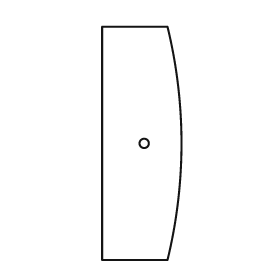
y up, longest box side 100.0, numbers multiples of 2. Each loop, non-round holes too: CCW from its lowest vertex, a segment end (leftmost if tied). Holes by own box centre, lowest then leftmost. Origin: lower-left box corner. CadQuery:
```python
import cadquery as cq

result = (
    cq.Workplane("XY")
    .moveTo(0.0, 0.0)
    .lineTo(28.0, 0.0)
    .threePointArc((34.0, 50.0), (28.0, 100.0))
    .lineTo(0.0, 100.0)
    .close()
    .moveTo(18.0, 50.0)
    .circle(2.0)
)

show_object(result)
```